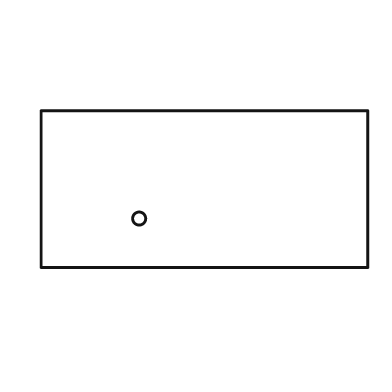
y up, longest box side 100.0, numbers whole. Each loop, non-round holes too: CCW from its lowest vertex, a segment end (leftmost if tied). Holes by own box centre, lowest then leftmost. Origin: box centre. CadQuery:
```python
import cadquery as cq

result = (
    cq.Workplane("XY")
    .moveTo(-50.0, -24.0)
    .lineTo(50.0, -24.0)
    .lineTo(50.0, 24.0)
    .lineTo(-50.0, 24.0)
    .close()
    .moveTo(-20.0, -9.0)
    .circle(2.0)
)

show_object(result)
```